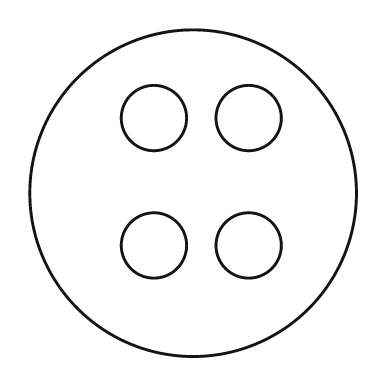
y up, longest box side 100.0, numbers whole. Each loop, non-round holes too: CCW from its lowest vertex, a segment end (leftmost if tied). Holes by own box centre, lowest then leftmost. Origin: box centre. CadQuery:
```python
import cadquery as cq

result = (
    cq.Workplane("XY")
    .moveTo(0.0, 0.0)
    .circle(50.0)
    .moveTo(-12.0, -16.0)
    .circle(10.0)
    .moveTo(17.0, -16.0)
    .circle(10.0)
    .moveTo(-12.0, 23.0)
    .circle(10.0)
    .moveTo(17.0, 23.0)
    .circle(10.0)
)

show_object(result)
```